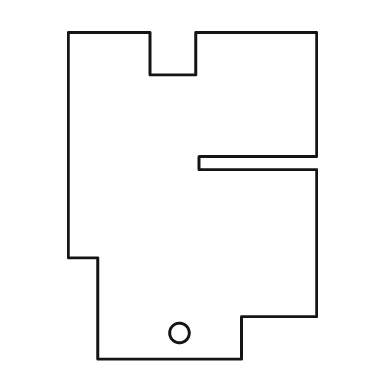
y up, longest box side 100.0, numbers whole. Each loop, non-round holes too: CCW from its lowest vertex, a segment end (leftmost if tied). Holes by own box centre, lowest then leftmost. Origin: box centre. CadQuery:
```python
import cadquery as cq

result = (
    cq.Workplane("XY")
    .moveTo(-29.0, -50.0)
    .lineTo(15.0, -50.0)
    .lineTo(15.0, -37.0)
    .lineTo(38.0, -37.0)
    .lineTo(38.0, 8.0)
    .lineTo(2.0, 8.0)
    .lineTo(2.0, 12.0)
    .lineTo(38.0, 12.0)
    .lineTo(38.0, 50.0)
    .lineTo(1.0, 50.0)
    .lineTo(1.0, 37.0)
    .lineTo(-13.0, 37.0)
    .lineTo(-13.0, 50.0)
    .lineTo(-38.0, 50.0)
    .lineTo(-38.0, -19.0)
    .lineTo(-29.0, -19.0)
    .close()
    .moveTo(-4.0, -42.0)
    .circle(3.0)
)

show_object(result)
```